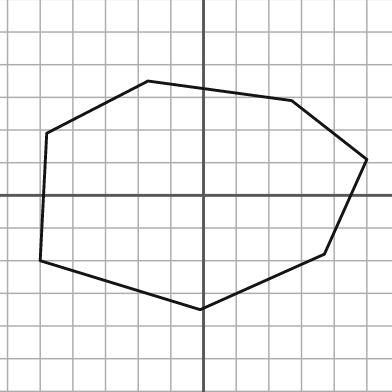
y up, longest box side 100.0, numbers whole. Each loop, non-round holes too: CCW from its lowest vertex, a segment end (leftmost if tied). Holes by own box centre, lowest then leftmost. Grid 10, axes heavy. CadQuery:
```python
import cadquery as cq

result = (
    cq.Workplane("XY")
    .moveTo(-1.0, -35.0)
    .lineTo(37.0, -18.0)
    .lineTo(50.0, 11.0)
    .lineTo(27.0, 29.0)
    .lineTo(-17.0, 35.0)
    .lineTo(-48.0, 19.0)
    .lineTo(-50.0, -20.0)
    .close()
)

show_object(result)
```